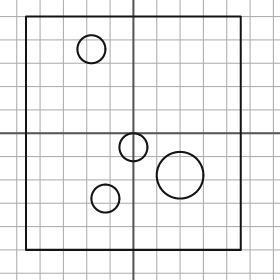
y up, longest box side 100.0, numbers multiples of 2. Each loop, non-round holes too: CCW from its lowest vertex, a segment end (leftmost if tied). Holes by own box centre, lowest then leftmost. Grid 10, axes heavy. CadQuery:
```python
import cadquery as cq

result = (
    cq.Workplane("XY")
    .moveTo(-46.0, -50.0)
    .lineTo(46.0, -50.0)
    .lineTo(46.0, 50.0)
    .lineTo(-46.0, 50.0)
    .close()
    .moveTo(-12.0, -28.0)
    .circle(6.0)
    .moveTo(20.0, -18.0)
    .circle(10.0)
    .moveTo(0.0, -6.0)
    .circle(6.0)
    .moveTo(-18.0, 36.0)
    .circle(6.0)
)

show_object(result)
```